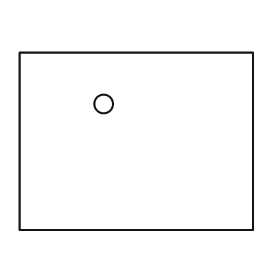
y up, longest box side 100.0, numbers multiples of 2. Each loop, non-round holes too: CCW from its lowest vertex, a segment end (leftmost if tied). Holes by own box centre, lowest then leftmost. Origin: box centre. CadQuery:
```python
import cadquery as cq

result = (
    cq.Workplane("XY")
    .moveTo(-50.0, -38.0)
    .lineTo(50.0, -38.0)
    .lineTo(50.0, 38.0)
    .lineTo(-50.0, 38.0)
    .close()
    .moveTo(-14.0, 16.0)
    .circle(4.0)
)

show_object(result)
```